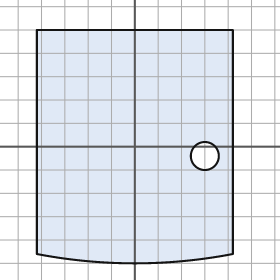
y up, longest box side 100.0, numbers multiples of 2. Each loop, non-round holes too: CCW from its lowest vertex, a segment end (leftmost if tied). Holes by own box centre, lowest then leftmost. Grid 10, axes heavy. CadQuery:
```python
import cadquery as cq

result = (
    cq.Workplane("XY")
    .moveTo(-42.0, -46.0)
    .threePointArc((0.0, -50.0), (42.0, -46.0))
    .lineTo(42.0, 50.0)
    .lineTo(-42.0, 50.0)
    .close()
    .moveTo(30.0, -4.0)
    .circle(6.0)
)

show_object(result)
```